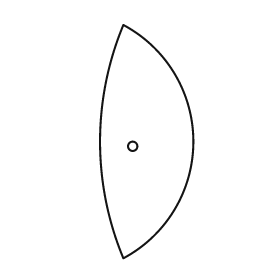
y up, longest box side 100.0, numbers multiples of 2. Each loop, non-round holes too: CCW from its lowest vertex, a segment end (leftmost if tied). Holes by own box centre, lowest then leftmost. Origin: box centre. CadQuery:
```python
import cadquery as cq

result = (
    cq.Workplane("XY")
    .moveTo(-10.0, -50.0)
    .threePointArc((20.0, 0.0), (-10.0, 50.0))
    .threePointArc((-20.0, 0.0), (-10.0, -50.0))
    .close()
    .moveTo(-6.0, -2.0)
    .circle(2.0)
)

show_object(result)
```